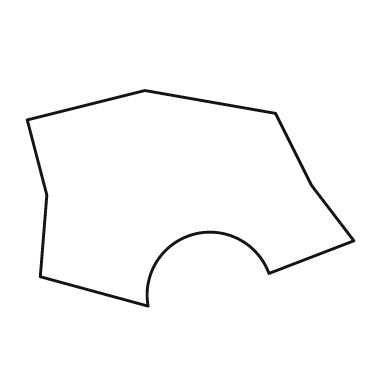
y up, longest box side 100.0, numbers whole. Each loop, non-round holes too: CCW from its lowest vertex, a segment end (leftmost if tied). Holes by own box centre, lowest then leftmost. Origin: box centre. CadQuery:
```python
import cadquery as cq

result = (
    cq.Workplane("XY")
    .moveTo(-13.0, -33.0)
    .threePointArc((1.0, -11.0), (24.0, -23.0))
    .lineTo(50.0, -13.0)
    .lineTo(37.0, 4.0)
    .lineTo(26.0, 26.0)
    .lineTo(-14.0, 33.0)
    .lineTo(-50.0, 24.0)
    .lineTo(-44.0, 1.0)
    .lineTo(-46.0, -24.0)
    .close()
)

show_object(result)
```